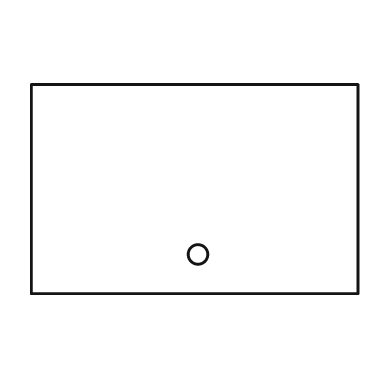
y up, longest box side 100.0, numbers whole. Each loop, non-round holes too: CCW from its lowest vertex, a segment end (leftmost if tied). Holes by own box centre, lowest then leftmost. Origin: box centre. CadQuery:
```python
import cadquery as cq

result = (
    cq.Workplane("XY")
    .moveTo(-50.0, -32.0)
    .lineTo(50.0, -32.0)
    .lineTo(50.0, 32.0)
    .lineTo(-50.0, 32.0)
    .close()
    .moveTo(1.0, -20.0)
    .circle(3.0)
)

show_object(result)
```